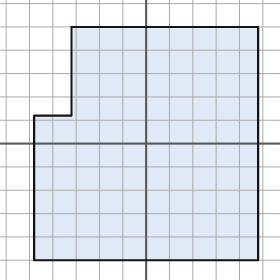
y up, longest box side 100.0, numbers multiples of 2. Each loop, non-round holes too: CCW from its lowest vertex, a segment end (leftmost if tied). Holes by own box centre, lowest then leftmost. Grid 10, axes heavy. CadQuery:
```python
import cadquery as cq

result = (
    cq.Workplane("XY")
    .moveTo(-48.0, -50.0)
    .lineTo(48.0, -50.0)
    .lineTo(48.0, 50.0)
    .lineTo(-32.0, 50.0)
    .lineTo(-32.0, 12.0)
    .lineTo(-48.0, 12.0)
    .close()
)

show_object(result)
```